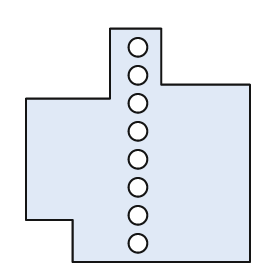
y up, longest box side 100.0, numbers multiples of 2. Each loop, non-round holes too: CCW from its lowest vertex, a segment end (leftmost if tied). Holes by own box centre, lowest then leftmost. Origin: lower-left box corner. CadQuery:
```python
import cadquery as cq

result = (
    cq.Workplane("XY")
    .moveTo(20.0, 0.0)
    .lineTo(96.0, 0.0)
    .lineTo(96.0, 76.0)
    .lineTo(58.0, 76.0)
    .lineTo(58.0, 100.0)
    .lineTo(36.0, 100.0)
    .lineTo(36.0, 70.0)
    .lineTo(0.0, 70.0)
    .lineTo(0.0, 18.0)
    .lineTo(20.0, 18.0)
    .close()
    .moveTo(48.0, 8.0)
    .circle(4.0)
    .moveTo(48.0, 20.0)
    .circle(4.0)
    .moveTo(48.0, 32.0)
    .circle(4.0)
    .moveTo(48.0, 44.0)
    .circle(4.0)
    .moveTo(48.0, 56.0)
    .circle(4.0)
    .moveTo(48.0, 68.0)
    .circle(4.0)
    .moveTo(48.0, 80.0)
    .circle(4.0)
    .moveTo(48.0, 92.0)
    .circle(4.0)
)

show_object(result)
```